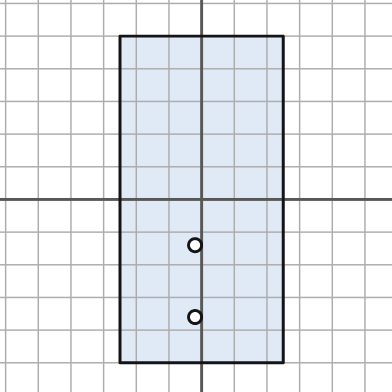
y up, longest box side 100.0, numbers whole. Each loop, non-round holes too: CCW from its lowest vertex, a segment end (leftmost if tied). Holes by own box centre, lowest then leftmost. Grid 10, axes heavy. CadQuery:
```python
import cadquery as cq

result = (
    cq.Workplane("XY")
    .moveTo(-25.0, -50.0)
    .lineTo(25.0, -50.0)
    .lineTo(25.0, 50.0)
    .lineTo(-25.0, 50.0)
    .close()
    .moveTo(-2.0, -36.0)
    .circle(2.0)
    .moveTo(-2.0, -14.0)
    .circle(2.0)
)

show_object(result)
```